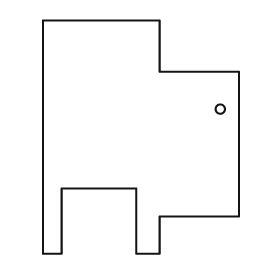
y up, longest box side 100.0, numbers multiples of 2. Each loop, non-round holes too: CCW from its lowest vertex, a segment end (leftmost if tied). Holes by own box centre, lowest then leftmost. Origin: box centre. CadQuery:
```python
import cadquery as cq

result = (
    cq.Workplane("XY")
    .moveTo(-42.0, -50.0)
    .lineTo(-34.0, -50.0)
    .lineTo(-34.0, -22.0)
    .lineTo(-2.0, -22.0)
    .lineTo(-2.0, -50.0)
    .lineTo(8.0, -50.0)
    .lineTo(8.0, -34.0)
    .lineTo(42.0, -34.0)
    .lineTo(42.0, 28.0)
    .lineTo(8.0, 28.0)
    .lineTo(8.0, 50.0)
    .lineTo(-42.0, 50.0)
    .close()
    .moveTo(34.0, 12.0)
    .circle(2.0)
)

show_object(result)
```